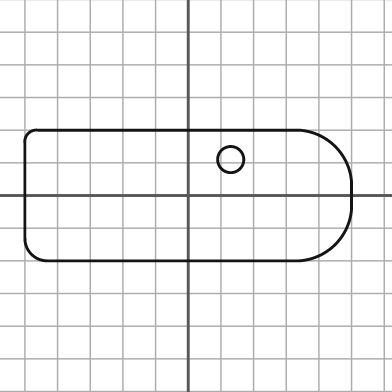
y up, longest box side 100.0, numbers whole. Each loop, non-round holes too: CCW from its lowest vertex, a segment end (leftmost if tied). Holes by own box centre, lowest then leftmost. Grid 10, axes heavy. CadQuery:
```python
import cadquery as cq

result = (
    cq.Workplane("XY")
    .moveTo(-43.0, -20.0)
    .lineTo(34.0, -20.0)
    .threePointArc((45.0, -15.0), (50.0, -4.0))
    .lineTo(50.0, 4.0)
    .threePointArc((45.0, 15.0), (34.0, 20.0))
    .lineTo(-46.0, 20.0)
    .threePointArc((-49.0, 19.0), (-50.0, 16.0))
    .lineTo(-50.0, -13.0)
    .threePointArc((-48.0, -18.0), (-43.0, -20.0))
    .close()
    .moveTo(13.0, 11.0)
    .circle(4.0)
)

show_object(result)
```